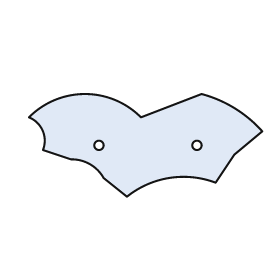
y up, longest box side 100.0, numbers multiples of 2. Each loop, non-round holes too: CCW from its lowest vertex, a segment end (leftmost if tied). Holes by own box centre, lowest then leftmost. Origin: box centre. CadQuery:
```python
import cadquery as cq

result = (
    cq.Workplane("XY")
    .moveTo(-8.0, -22.0)
    .threePointArc((10.0, -14.0), (30.0, -16.0))
    .lineTo(38.0, -4.0)
    .lineTo(50.0, 6.0)
    .threePointArc((38.0, 16.0), (24.0, 22.0))
    .lineTo(-2.0, 12.0)
    .threePointArc((-26.0, 22.0), (-50.0, 12.0))
    .threePointArc((-44.0, 6.0), (-44.0, -2.0))
    .lineTo(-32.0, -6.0)
    .threePointArc((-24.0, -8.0), (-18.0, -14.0))
    .close()
    .moveTo(-20.0, 0.0)
    .circle(2.0)
    .moveTo(22.0, 0.0)
    .circle(2.0)
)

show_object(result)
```